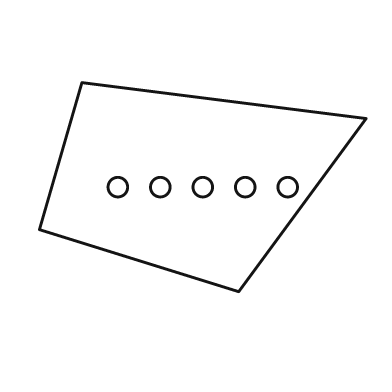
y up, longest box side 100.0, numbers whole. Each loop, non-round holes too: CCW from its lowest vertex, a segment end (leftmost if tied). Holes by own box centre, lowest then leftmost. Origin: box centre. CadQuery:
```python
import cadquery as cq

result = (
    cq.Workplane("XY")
    .moveTo(11.0, -32.0)
    .lineTo(50.0, 21.0)
    .lineTo(-37.0, 32.0)
    .lineTo(-50.0, -13.0)
    .close()
    .moveTo(-26.0, 0.0)
    .circle(3.0)
    .moveTo(-13.0, 0.0)
    .circle(3.0)
    .moveTo(0.0, 0.0)
    .circle(3.0)
    .moveTo(13.0, 0.0)
    .circle(3.0)
    .moveTo(26.0, 0.0)
    .circle(3.0)
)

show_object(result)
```